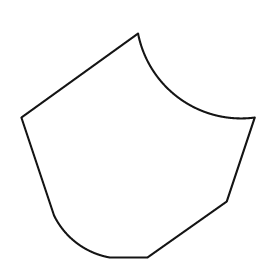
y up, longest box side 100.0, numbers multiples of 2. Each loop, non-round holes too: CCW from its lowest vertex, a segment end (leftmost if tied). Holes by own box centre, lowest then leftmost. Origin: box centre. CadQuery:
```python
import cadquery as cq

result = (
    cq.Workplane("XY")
    .moveTo(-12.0, -48.0)
    .lineTo(4.0, -48.0)
    .lineTo(38.0, -24.0)
    .lineTo(50.0, 12.0)
    .threePointArc((18.0, 20.0), (0.0, 48.0))
    .lineTo(-50.0, 12.0)
    .lineTo(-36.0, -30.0)
    .threePointArc((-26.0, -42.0), (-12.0, -48.0))
    .close()
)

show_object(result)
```